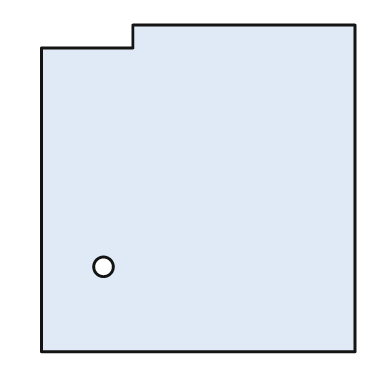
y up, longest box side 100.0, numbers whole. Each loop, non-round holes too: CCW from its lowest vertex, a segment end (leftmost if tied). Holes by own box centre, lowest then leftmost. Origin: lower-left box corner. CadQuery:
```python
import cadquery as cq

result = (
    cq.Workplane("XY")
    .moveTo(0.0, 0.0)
    .lineTo(96.0, 0.0)
    .lineTo(96.0, 100.0)
    .lineTo(28.0, 100.0)
    .lineTo(28.0, 93.0)
    .lineTo(0.0, 93.0)
    .close()
    .moveTo(19.0, 26.0)
    .circle(3.0)
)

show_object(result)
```